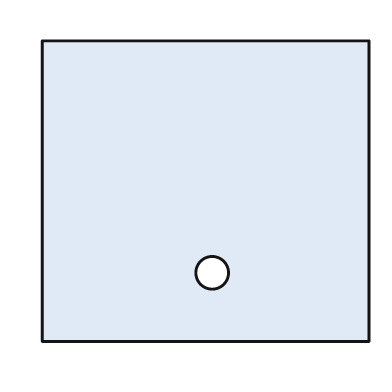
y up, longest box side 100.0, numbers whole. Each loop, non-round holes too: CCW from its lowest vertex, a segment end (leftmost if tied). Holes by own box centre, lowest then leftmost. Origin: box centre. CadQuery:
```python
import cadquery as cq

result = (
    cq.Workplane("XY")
    .moveTo(-50.0, -46.0)
    .lineTo(50.0, -46.0)
    .lineTo(50.0, 46.0)
    .lineTo(-50.0, 46.0)
    .close()
    .moveTo(2.0, -25.0)
    .circle(5.0)
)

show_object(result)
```